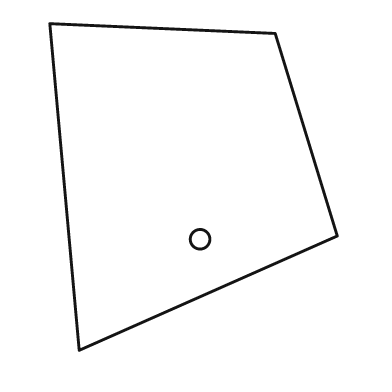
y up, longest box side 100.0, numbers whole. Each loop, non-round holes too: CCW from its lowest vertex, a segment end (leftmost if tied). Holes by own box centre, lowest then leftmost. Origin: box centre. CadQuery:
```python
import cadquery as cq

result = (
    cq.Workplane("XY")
    .moveTo(-35.0, -50.0)
    .lineTo(44.0, -15.0)
    .lineTo(25.0, 47.0)
    .lineTo(-44.0, 50.0)
    .close()
    .moveTo(2.0, -16.0)
    .circle(3.0)
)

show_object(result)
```